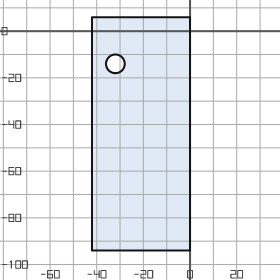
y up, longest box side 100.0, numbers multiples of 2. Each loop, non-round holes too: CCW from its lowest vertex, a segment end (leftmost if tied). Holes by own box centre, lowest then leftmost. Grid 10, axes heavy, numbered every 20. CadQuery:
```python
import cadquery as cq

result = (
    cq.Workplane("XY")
    .moveTo(-42.0, -94.0)
    .lineTo(0.0, -94.0)
    .lineTo(0.0, 6.0)
    .lineTo(-42.0, 6.0)
    .close()
    .moveTo(-32.0, -14.0)
    .circle(4.0)
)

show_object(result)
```